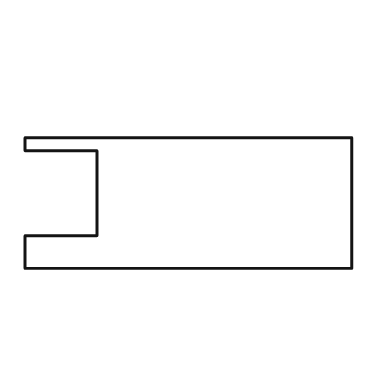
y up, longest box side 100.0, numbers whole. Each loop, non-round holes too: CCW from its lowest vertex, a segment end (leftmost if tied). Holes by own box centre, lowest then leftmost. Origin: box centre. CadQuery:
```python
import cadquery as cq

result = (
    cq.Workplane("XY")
    .moveTo(-50.0, -20.0)
    .lineTo(50.0, -20.0)
    .lineTo(50.0, 20.0)
    .lineTo(-50.0, 20.0)
    .lineTo(-50.0, 16.0)
    .lineTo(-28.0, 16.0)
    .lineTo(-28.0, -10.0)
    .lineTo(-50.0, -10.0)
    .close()
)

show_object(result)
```